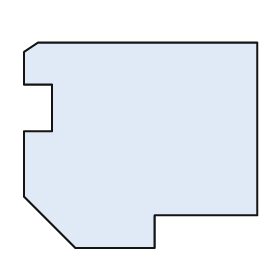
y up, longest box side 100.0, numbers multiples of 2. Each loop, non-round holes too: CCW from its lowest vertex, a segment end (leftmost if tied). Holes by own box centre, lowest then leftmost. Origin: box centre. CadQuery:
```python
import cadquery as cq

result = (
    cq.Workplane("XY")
    .moveTo(-28.0, -44.0)
    .lineTo(6.0, -44.0)
    .lineTo(6.0, -30.0)
    .lineTo(50.0, -30.0)
    .lineTo(50.0, 44.0)
    .lineTo(-44.0, 44.0)
    .lineTo(-50.0, 40.0)
    .lineTo(-50.0, 26.0)
    .lineTo(-38.0, 26.0)
    .lineTo(-38.0, 6.0)
    .lineTo(-50.0, 6.0)
    .lineTo(-50.0, -22.0)
    .close()
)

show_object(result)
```